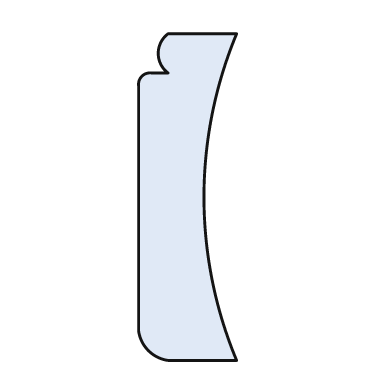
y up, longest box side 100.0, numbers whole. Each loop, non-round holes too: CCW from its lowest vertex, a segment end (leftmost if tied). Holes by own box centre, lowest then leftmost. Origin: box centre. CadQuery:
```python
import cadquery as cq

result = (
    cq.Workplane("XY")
    .moveTo(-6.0, -50.0)
    .lineTo(15.0, -50.0)
    .threePointArc((5.0, 0.0), (15.0, 50.0))
    .lineTo(-6.0, 50.0)
    .threePointArc((-9.0, 44.0), (-6.0, 38.0))
    .lineTo(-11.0, 38.0)
    .threePointArc((-14.0, 37.0), (-15.0, 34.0))
    .lineTo(-15.0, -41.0)
    .threePointArc((-12.0, -47.0), (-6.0, -50.0))
    .close()
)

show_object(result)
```